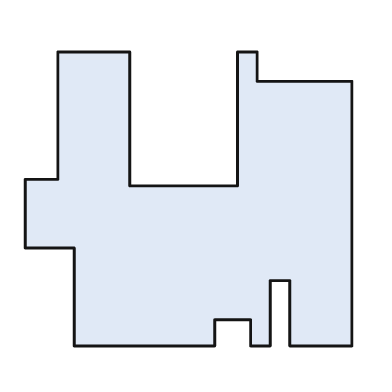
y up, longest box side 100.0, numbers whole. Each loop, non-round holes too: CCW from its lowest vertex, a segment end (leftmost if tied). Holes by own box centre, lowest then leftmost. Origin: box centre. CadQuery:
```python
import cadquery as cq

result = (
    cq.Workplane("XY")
    .moveTo(-35.0, -45.0)
    .lineTo(8.0, -45.0)
    .lineTo(8.0, -37.0)
    .lineTo(19.0, -37.0)
    .lineTo(19.0, -45.0)
    .lineTo(25.0, -45.0)
    .lineTo(25.0, -25.0)
    .lineTo(31.0, -25.0)
    .lineTo(31.0, -45.0)
    .lineTo(50.0, -45.0)
    .lineTo(50.0, 36.0)
    .lineTo(21.0, 36.0)
    .lineTo(21.0, 45.0)
    .lineTo(15.0, 45.0)
    .lineTo(15.0, 4.0)
    .lineTo(-18.0, 4.0)
    .lineTo(-18.0, 45.0)
    .lineTo(-40.0, 45.0)
    .lineTo(-40.0, 6.0)
    .lineTo(-50.0, 6.0)
    .lineTo(-50.0, -15.0)
    .lineTo(-35.0, -15.0)
    .close()
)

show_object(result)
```